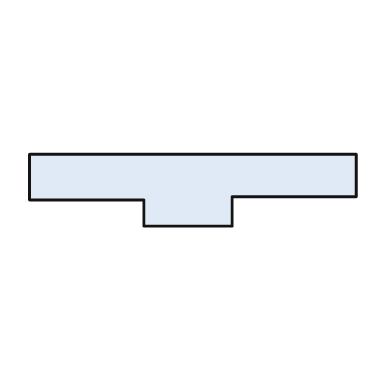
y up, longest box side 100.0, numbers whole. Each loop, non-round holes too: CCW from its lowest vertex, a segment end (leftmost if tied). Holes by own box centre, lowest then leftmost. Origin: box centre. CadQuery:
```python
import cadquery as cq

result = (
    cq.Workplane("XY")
    .moveTo(-15.0, -11.0)
    .lineTo(12.0, -11.0)
    .lineTo(12.0, -2.0)
    .lineTo(50.0, -2.0)
    .lineTo(50.0, 11.0)
    .lineTo(-50.0, 11.0)
    .lineTo(-50.0, -3.0)
    .lineTo(-15.0, -3.0)
    .close()
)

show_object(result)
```